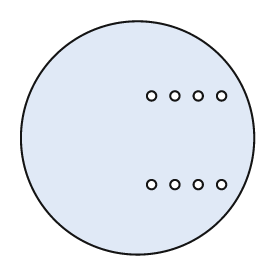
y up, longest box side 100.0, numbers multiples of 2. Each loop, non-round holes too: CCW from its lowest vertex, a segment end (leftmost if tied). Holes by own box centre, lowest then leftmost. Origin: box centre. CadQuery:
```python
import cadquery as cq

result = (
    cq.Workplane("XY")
    .moveTo(0.0, 0.0)
    .circle(50.0)
    .moveTo(6.0, -20.0)
    .circle(2.0)
    .moveTo(16.0, -20.0)
    .circle(2.0)
    .moveTo(26.0, -20.0)
    .circle(2.0)
    .moveTo(36.0, -20.0)
    .circle(2.0)
    .moveTo(6.0, 18.0)
    .circle(2.0)
    .moveTo(16.0, 18.0)
    .circle(2.0)
    .moveTo(26.0, 18.0)
    .circle(2.0)
    .moveTo(36.0, 18.0)
    .circle(2.0)
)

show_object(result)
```